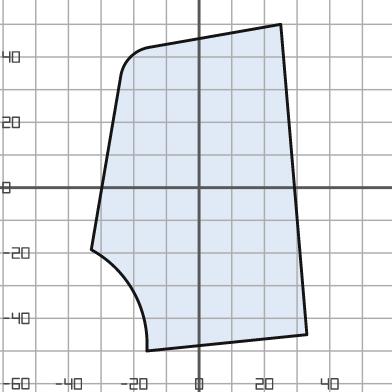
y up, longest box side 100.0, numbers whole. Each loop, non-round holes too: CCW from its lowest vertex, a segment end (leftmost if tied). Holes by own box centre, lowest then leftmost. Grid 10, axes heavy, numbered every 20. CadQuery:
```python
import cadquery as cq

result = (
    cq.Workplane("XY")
    .moveTo(-16.0, -50.0)
    .lineTo(33.0, -45.0)
    .lineTo(25.0, 50.0)
    .lineTo(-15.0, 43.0)
    .threePointArc((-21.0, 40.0), (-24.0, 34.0))
    .lineTo(-33.0, -19.0)
    .threePointArc((-20.0, -32.0), (-16.0, -50.0))
    .close()
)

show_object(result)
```